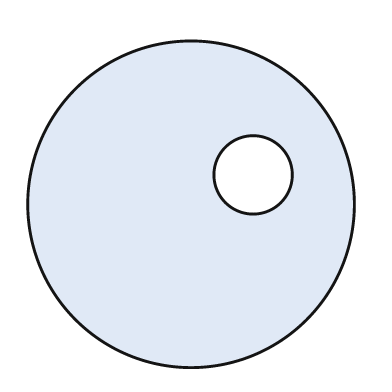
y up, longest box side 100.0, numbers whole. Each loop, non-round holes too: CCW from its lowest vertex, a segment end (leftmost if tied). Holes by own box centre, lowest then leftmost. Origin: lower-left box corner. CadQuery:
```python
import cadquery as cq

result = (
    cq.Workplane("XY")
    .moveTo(50.0, 50.0)
    .circle(50.0)
    .moveTo(69.0, 59.0)
    .circle(12.0)
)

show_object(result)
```